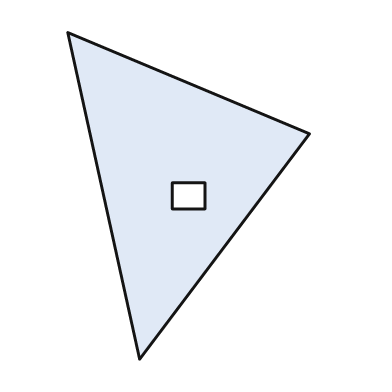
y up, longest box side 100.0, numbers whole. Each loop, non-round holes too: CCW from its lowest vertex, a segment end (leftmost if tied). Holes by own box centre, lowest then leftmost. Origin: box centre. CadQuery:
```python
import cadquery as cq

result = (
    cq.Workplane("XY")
    .moveTo(-15.0, -50.0)
    .lineTo(37.0, 19.0)
    .lineTo(-37.0, 50.0)
    .close()
    .moveTo(-5.0, -4.0)
    .lineTo(5.0, -4.0)
    .lineTo(5.0, 4.0)
    .lineTo(-5.0, 4.0)
    .close()
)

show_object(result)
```